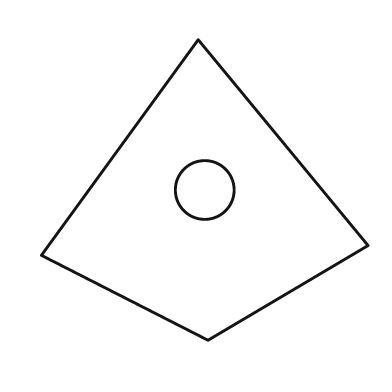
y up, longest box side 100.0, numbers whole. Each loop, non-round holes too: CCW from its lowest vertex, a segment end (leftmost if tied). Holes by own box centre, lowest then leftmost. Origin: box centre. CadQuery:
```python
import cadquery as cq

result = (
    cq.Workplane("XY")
    .moveTo(1.0, -46.0)
    .lineTo(50.0, -17.0)
    .lineTo(-2.0, 46.0)
    .lineTo(-50.0, -20.0)
    .close()
    .moveTo(0.0, 0.0)
    .circle(9.0)
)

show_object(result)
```